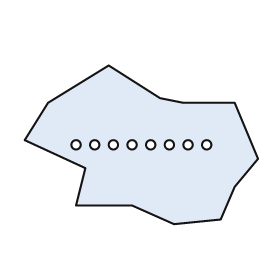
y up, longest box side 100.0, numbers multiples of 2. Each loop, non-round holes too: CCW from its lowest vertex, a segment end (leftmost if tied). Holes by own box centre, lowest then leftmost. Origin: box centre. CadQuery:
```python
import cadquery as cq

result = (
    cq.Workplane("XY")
    .moveTo(14.0, -34.0)
    .lineTo(34.0, -32.0)
    .lineTo(40.0, -18.0)
    .lineTo(50.0, -6.0)
    .lineTo(40.0, 18.0)
    .lineTo(18.0, 18.0)
    .lineTo(8.0, 20.0)
    .lineTo(-14.0, 34.0)
    .lineTo(-40.0, 18.0)
    .lineTo(-50.0, 2.0)
    .lineTo(-24.0, -10.0)
    .lineTo(-28.0, -26.0)
    .lineTo(-4.0, -26.0)
    .close()
    .moveTo(-28.0, 0.0)
    .circle(2.0)
    .moveTo(-20.0, 0.0)
    .circle(2.0)
    .moveTo(-12.0, 0.0)
    .circle(2.0)
    .moveTo(-4.0, 0.0)
    .circle(2.0)
    .moveTo(4.0, 0.0)
    .circle(2.0)
    .moveTo(12.0, 0.0)
    .circle(2.0)
    .moveTo(20.0, 0.0)
    .circle(2.0)
    .moveTo(28.0, 0.0)
    .circle(2.0)
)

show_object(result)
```